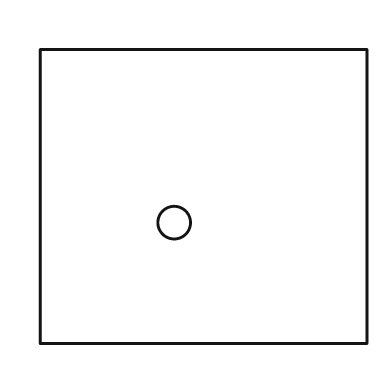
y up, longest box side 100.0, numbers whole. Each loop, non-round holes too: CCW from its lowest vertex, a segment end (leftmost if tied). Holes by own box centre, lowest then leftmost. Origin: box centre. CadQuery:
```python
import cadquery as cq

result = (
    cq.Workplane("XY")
    .moveTo(-50.0, -45.0)
    .lineTo(50.0, -45.0)
    .lineTo(50.0, 45.0)
    .lineTo(-50.0, 45.0)
    .close()
    .moveTo(-9.0, -8.0)
    .circle(5.0)
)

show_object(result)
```